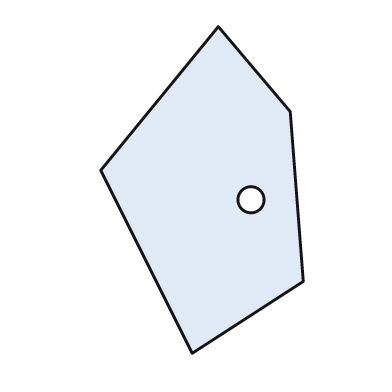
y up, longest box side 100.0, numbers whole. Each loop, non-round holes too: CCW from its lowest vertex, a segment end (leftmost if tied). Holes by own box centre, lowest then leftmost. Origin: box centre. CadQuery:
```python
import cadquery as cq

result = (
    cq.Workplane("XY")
    .moveTo(-3.0, -50.0)
    .lineTo(31.0, -28.0)
    .lineTo(27.0, 24.0)
    .lineTo(5.0, 50.0)
    .lineTo(-31.0, 6.0)
    .close()
    .moveTo(15.0, -3.0)
    .circle(4.0)
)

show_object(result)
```